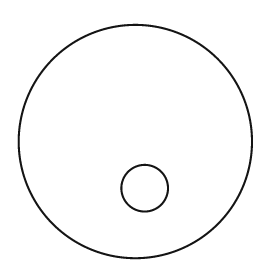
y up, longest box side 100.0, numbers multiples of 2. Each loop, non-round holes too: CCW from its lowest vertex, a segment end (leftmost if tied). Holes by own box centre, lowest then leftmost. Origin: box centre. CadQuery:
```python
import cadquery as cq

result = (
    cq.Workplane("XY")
    .moveTo(0.0, 0.0)
    .circle(50.0)
    .moveTo(4.0, -20.0)
    .circle(10.0)
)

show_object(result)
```